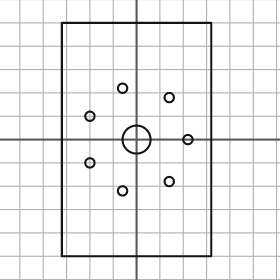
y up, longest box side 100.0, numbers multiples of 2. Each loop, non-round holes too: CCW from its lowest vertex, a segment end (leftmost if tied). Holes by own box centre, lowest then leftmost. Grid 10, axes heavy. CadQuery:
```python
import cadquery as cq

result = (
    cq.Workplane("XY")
    .moveTo(-32.0, -50.0)
    .lineTo(32.0, -50.0)
    .lineTo(32.0, 50.0)
    .lineTo(-32.0, 50.0)
    .close()
    .moveTo(-6.0, -22.0)
    .circle(2.0)
    .moveTo(14.0, -18.0)
    .circle(2.0)
    .moveTo(-20.0, -10.0)
    .circle(2.0)
    .moveTo(0.0, 0.0)
    .circle(6.0)
    .moveTo(22.0, 0.0)
    .circle(2.0)
    .moveTo(-20.0, 10.0)
    .circle(2.0)
    .moveTo(14.0, 18.0)
    .circle(2.0)
    .moveTo(-6.0, 22.0)
    .circle(2.0)
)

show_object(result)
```